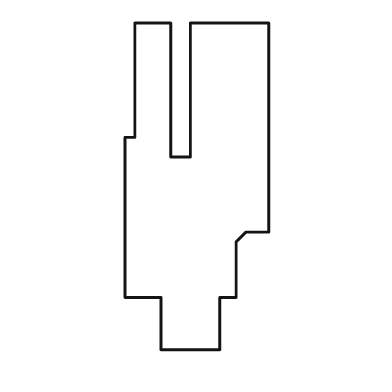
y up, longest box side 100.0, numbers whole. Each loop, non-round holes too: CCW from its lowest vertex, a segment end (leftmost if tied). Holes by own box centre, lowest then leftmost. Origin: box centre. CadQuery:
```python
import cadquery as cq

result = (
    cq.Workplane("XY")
    .moveTo(-11.0, -50.0)
    .lineTo(7.0, -50.0)
    .lineTo(7.0, -34.0)
    .lineTo(12.0, -34.0)
    .lineTo(12.0, -17.0)
    .lineTo(15.0, -14.0)
    .lineTo(22.0, -14.0)
    .lineTo(22.0, 50.0)
    .lineTo(-2.0, 50.0)
    .lineTo(-2.0, 9.0)
    .lineTo(-8.0, 9.0)
    .lineTo(-8.0, 50.0)
    .lineTo(-19.0, 50.0)
    .lineTo(-19.0, 15.0)
    .lineTo(-22.0, 15.0)
    .lineTo(-22.0, -34.0)
    .lineTo(-11.0, -34.0)
    .close()
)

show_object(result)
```